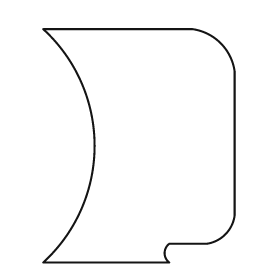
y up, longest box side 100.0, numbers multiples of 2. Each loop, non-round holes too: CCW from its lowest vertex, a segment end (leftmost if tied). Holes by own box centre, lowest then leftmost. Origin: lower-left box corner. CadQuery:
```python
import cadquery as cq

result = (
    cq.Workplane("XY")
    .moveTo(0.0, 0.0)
    .lineTo(54.0, 0.0)
    .threePointArc((52.0, 4.0), (54.0, 8.0))
    .lineTo(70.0, 8.0)
    .threePointArc((78.0, 12.0), (82.0, 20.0))
    .lineTo(82.0, 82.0)
    .threePointArc((76.0, 94.0), (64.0, 100.0))
    .lineTo(0.0, 100.0)
    .threePointArc((22.0, 50.0), (0.0, 0.0))
    .close()
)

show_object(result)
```